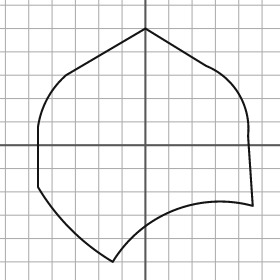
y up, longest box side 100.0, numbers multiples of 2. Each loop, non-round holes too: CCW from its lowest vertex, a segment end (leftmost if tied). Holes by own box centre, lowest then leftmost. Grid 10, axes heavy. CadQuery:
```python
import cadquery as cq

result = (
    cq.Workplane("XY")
    .moveTo(-14.0, -50.0)
    .threePointArc((12.0, -28.0), (46.0, -26.0))
    .lineTo(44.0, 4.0)
    .threePointArc((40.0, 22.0), (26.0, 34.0))
    .lineTo(0.0, 50.0)
    .lineTo(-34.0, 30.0)
    .threePointArc((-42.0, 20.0), (-46.0, 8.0))
    .lineTo(-46.0, -18.0)
    .threePointArc((-32.0, -36.0), (-14.0, -50.0))
    .close()
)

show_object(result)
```